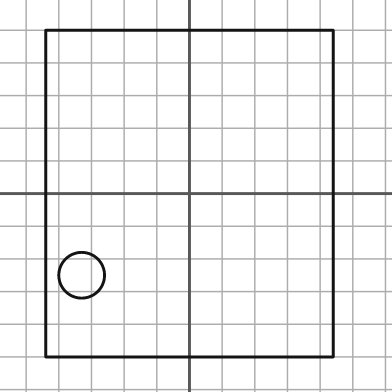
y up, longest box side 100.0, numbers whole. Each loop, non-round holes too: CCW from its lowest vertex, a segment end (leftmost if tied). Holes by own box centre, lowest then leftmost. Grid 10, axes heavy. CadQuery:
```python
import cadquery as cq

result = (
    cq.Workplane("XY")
    .moveTo(-44.0, -50.0)
    .lineTo(44.0, -50.0)
    .lineTo(44.0, 50.0)
    .lineTo(-44.0, 50.0)
    .close()
    .moveTo(-33.0, -25.0)
    .circle(7.0)
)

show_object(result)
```